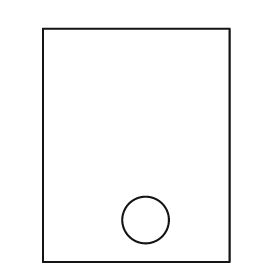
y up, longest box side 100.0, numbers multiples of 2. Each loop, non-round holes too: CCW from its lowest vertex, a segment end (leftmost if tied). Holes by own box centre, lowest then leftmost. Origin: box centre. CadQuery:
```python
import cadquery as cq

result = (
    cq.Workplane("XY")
    .moveTo(-40.0, -50.0)
    .lineTo(40.0, -50.0)
    .lineTo(40.0, 50.0)
    .lineTo(-40.0, 50.0)
    .close()
    .moveTo(4.0, -32.0)
    .circle(10.0)
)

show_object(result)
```